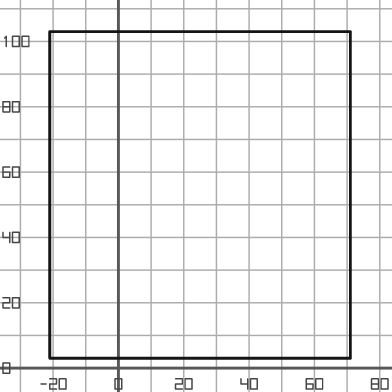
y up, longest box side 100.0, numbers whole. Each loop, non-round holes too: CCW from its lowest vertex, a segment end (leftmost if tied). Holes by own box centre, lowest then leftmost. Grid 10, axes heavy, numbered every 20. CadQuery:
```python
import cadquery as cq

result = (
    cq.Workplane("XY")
    .moveTo(-21.0, 3.0)
    .lineTo(71.0, 3.0)
    .lineTo(71.0, 103.0)
    .lineTo(-21.0, 103.0)
    .close()
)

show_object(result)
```